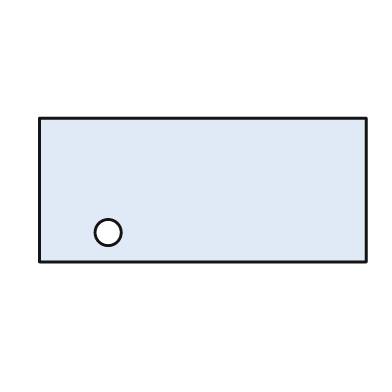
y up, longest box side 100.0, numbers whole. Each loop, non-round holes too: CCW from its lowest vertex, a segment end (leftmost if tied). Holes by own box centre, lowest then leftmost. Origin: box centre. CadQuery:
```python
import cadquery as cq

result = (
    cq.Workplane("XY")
    .moveTo(-50.0, -22.0)
    .lineTo(50.0, -22.0)
    .lineTo(50.0, 22.0)
    .lineTo(-50.0, 22.0)
    .close()
    .moveTo(-29.0, -13.0)
    .circle(4.0)
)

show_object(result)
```